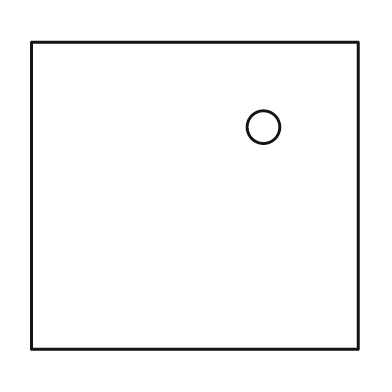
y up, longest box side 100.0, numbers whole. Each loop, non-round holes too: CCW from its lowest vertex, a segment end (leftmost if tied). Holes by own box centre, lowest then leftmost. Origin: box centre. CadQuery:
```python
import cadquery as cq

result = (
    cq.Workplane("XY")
    .moveTo(-50.0, -47.0)
    .lineTo(50.0, -47.0)
    .lineTo(50.0, 47.0)
    .lineTo(-50.0, 47.0)
    .close()
    .moveTo(21.0, 21.0)
    .circle(5.0)
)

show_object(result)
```